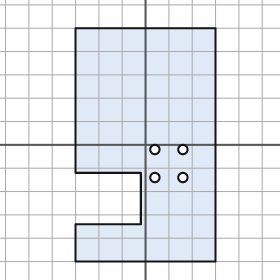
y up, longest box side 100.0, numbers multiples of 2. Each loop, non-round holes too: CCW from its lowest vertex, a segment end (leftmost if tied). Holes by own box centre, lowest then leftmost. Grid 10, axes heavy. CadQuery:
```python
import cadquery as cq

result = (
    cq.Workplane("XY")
    .moveTo(-30.0, -50.0)
    .lineTo(30.0, -50.0)
    .lineTo(30.0, 50.0)
    .lineTo(-30.0, 50.0)
    .lineTo(-30.0, -12.0)
    .lineTo(-2.0, -12.0)
    .lineTo(-2.0, -34.0)
    .lineTo(-30.0, -34.0)
    .close()
    .moveTo(4.0, -14.0)
    .circle(2.0)
    .moveTo(16.0, -14.0)
    .circle(2.0)
    .moveTo(4.0, -2.0)
    .circle(2.0)
    .moveTo(16.0, -2.0)
    .circle(2.0)
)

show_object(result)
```